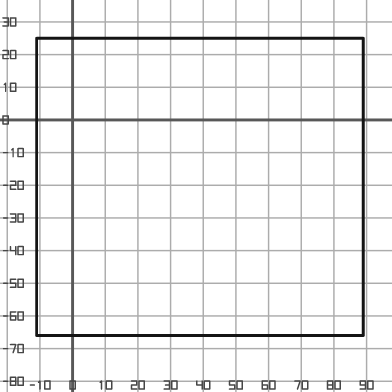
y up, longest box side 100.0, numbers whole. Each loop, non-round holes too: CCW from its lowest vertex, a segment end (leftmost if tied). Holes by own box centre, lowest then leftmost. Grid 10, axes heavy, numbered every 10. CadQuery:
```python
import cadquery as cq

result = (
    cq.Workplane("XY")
    .moveTo(-11.0, -66.0)
    .lineTo(89.0, -66.0)
    .lineTo(89.0, 25.0)
    .lineTo(-11.0, 25.0)
    .close()
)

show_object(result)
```